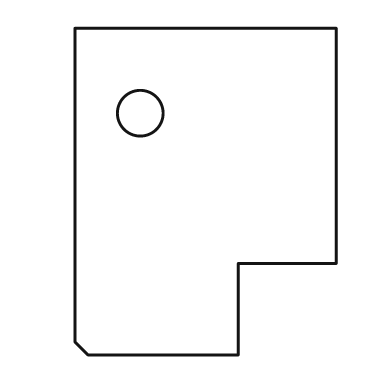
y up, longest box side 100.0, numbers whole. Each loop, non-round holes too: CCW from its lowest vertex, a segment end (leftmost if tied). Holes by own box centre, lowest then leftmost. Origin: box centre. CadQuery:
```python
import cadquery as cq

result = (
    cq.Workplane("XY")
    .moveTo(-36.0, -50.0)
    .lineTo(10.0, -50.0)
    .lineTo(10.0, -22.0)
    .lineTo(40.0, -22.0)
    .lineTo(40.0, 50.0)
    .lineTo(-40.0, 50.0)
    .lineTo(-40.0, -46.0)
    .close()
    .moveTo(-20.0, 24.0)
    .circle(7.0)
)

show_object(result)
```